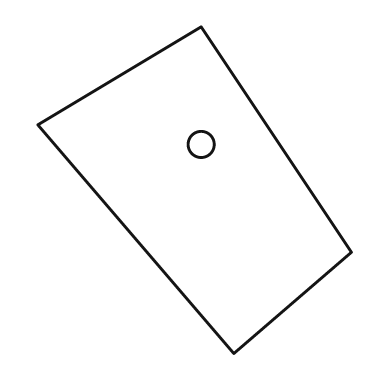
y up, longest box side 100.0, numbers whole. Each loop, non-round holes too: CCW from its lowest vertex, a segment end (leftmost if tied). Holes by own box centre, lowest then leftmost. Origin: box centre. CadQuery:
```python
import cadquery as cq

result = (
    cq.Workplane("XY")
    .moveTo(12.0, -50.0)
    .lineTo(48.0, -19.0)
    .lineTo(2.0, 50.0)
    .lineTo(-48.0, 20.0)
    .close()
    .moveTo(2.0, 14.0)
    .circle(4.0)
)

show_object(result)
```